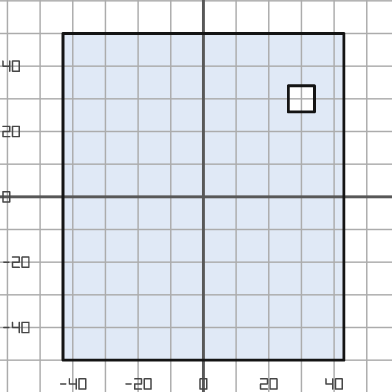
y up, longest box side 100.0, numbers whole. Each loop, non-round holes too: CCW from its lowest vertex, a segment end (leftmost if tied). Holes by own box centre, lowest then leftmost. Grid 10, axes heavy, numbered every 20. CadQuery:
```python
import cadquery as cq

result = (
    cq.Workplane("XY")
    .moveTo(-43.0, -50.0)
    .lineTo(43.0, -50.0)
    .lineTo(43.0, 50.0)
    .lineTo(-43.0, 50.0)
    .close()
    .moveTo(26.0, 26.0)
    .lineTo(34.0, 26.0)
    .lineTo(34.0, 34.0)
    .lineTo(26.0, 34.0)
    .close()
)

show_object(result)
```